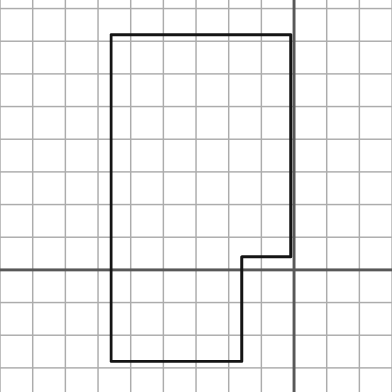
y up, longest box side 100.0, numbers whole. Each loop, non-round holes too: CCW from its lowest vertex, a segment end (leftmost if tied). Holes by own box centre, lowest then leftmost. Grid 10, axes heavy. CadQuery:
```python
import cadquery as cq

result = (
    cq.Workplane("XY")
    .moveTo(-56.0, -28.0)
    .lineTo(-16.0, -28.0)
    .lineTo(-16.0, 4.0)
    .lineTo(-1.0, 4.0)
    .lineTo(-1.0, 72.0)
    .lineTo(-56.0, 72.0)
    .close()
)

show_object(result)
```